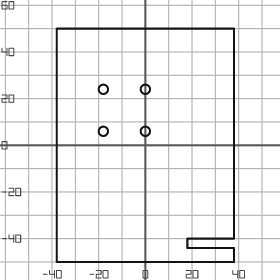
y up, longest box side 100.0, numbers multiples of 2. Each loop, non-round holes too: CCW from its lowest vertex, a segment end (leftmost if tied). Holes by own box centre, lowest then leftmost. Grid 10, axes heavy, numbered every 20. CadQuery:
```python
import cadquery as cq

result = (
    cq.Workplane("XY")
    .moveTo(-38.0, -50.0)
    .lineTo(38.0, -50.0)
    .lineTo(38.0, -44.0)
    .lineTo(18.0, -44.0)
    .lineTo(18.0, -40.0)
    .lineTo(38.0, -40.0)
    .lineTo(38.0, 50.0)
    .lineTo(-38.0, 50.0)
    .close()
    .moveTo(-18.0, 6.0)
    .circle(2.0)
    .moveTo(0.0, 6.0)
    .circle(2.0)
    .moveTo(-18.0, 24.0)
    .circle(2.0)
    .moveTo(0.0, 24.0)
    .circle(2.0)
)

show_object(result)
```